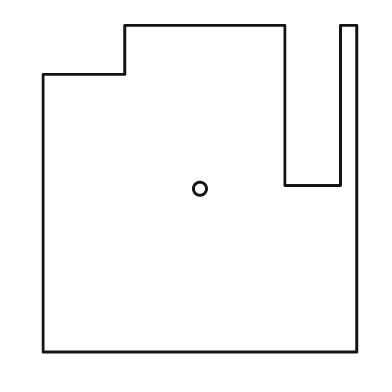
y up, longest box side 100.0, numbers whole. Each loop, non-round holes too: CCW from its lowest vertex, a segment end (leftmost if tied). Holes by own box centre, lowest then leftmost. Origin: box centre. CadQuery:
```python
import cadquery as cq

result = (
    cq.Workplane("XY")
    .moveTo(-48.0, -50.0)
    .lineTo(48.0, -50.0)
    .lineTo(48.0, 50.0)
    .lineTo(43.0, 50.0)
    .lineTo(43.0, 1.0)
    .lineTo(26.0, 1.0)
    .lineTo(26.0, 50.0)
    .lineTo(-23.0, 50.0)
    .lineTo(-23.0, 35.0)
    .lineTo(-48.0, 35.0)
    .close()
    .moveTo(0.0, 0.0)
    .circle(2.0)
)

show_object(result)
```